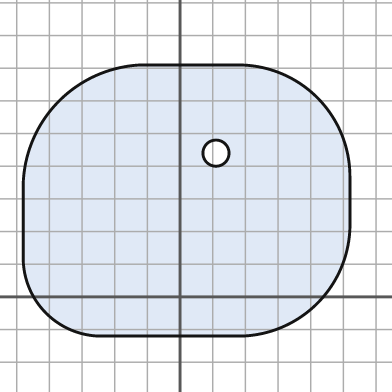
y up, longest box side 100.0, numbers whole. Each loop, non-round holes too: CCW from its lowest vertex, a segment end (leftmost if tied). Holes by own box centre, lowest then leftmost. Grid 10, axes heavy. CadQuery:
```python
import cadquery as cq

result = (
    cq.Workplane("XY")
    .moveTo(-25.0, -12.0)
    .lineTo(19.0, -12.0)
    .threePointArc((42.0, -2.0), (52.0, 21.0))
    .lineTo(52.0, 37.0)
    .threePointArc((42.0, 61.0), (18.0, 71.0))
    .lineTo(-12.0, 71.0)
    .threePointArc((-37.0, 60.0), (-48.0, 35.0))
    .lineTo(-48.0, 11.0)
    .threePointArc((-41.0, -5.0), (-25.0, -12.0))
    .close()
    .moveTo(11.0, 44.0)
    .circle(4.0)
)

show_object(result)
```